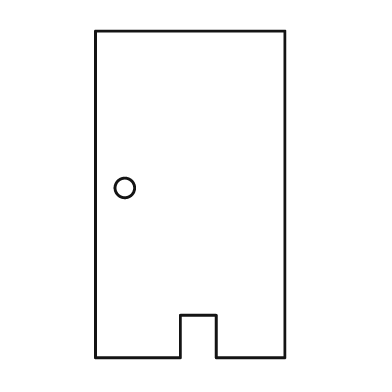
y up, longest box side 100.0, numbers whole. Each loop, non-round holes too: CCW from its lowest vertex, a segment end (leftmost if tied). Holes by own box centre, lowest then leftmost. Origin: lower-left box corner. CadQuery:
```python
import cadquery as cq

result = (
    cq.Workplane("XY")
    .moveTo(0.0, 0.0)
    .lineTo(26.0, 0.0)
    .lineTo(26.0, 13.0)
    .lineTo(37.0, 13.0)
    .lineTo(37.0, 0.0)
    .lineTo(58.0, 0.0)
    .lineTo(58.0, 100.0)
    .lineTo(0.0, 100.0)
    .close()
    .moveTo(9.0, 52.0)
    .circle(3.0)
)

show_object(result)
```